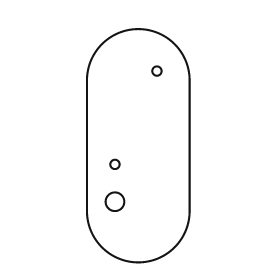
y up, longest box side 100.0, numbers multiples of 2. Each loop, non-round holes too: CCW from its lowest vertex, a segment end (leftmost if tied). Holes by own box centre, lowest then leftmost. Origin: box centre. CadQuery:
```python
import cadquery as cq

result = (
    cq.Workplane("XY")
    .moveTo(-22.0, -28.0)
    .threePointArc((0.0, -50.0), (22.0, -28.0))
    .lineTo(22.0, 28.0)
    .threePointArc((0.0, 50.0), (-22.0, 28.0))
    .close()
    .moveTo(-10.0, -24.0)
    .circle(4.0)
    .moveTo(-10.0, -8.0)
    .circle(2.0)
    .moveTo(8.0, 32.0)
    .circle(2.0)
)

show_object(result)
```